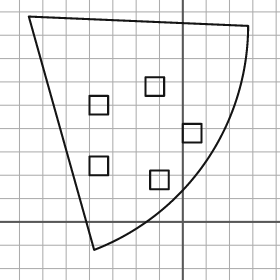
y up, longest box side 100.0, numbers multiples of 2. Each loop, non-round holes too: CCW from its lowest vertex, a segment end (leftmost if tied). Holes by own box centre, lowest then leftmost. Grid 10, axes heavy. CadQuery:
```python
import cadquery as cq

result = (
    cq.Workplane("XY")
    .moveTo(-38.0, -12.0)
    .threePointArc((10.0, 26.0), (28.0, 84.0))
    .lineTo(-66.0, 88.0)
    .close()
    .moveTo(-14.0, 14.0)
    .lineTo(-6.0, 14.0)
    .lineTo(-6.0, 22.0)
    .lineTo(-14.0, 22.0)
    .close()
    .moveTo(-40.0, 20.0)
    .lineTo(-32.0, 20.0)
    .lineTo(-32.0, 28.0)
    .lineTo(-40.0, 28.0)
    .close()
    .moveTo(0.0, 34.0)
    .lineTo(8.0, 34.0)
    .lineTo(8.0, 42.0)
    .lineTo(0.0, 42.0)
    .close()
    .moveTo(-40.0, 46.0)
    .lineTo(-32.0, 46.0)
    .lineTo(-32.0, 54.0)
    .lineTo(-40.0, 54.0)
    .close()
    .moveTo(-16.0, 54.0)
    .lineTo(-8.0, 54.0)
    .lineTo(-8.0, 62.0)
    .lineTo(-16.0, 62.0)
    .close()
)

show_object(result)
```